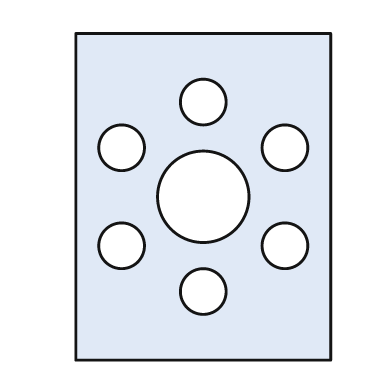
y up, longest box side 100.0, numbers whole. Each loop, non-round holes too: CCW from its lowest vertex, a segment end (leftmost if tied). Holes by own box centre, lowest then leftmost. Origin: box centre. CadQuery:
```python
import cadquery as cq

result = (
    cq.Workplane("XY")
    .moveTo(-39.0, -50.0)
    .lineTo(39.0, -50.0)
    .lineTo(39.0, 50.0)
    .lineTo(-39.0, 50.0)
    .close()
    .moveTo(0.0, -29.0)
    .circle(7.0)
    .moveTo(-25.0, -15.0)
    .circle(7.0)
    .moveTo(25.0, -15.0)
    .circle(7.0)
    .moveTo(0.0, 0.0)
    .circle(14.0)
    .moveTo(-25.0, 15.0)
    .circle(7.0)
    .moveTo(25.0, 15.0)
    .circle(7.0)
    .moveTo(0.0, 29.0)
    .circle(7.0)
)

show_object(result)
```